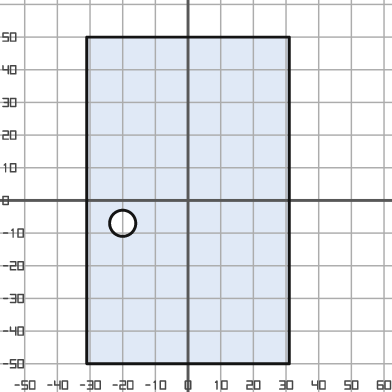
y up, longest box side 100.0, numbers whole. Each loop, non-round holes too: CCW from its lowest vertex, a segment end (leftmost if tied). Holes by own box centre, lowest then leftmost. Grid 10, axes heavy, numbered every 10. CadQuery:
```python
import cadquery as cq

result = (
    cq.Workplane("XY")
    .moveTo(-31.0, -50.0)
    .lineTo(31.0, -50.0)
    .lineTo(31.0, 50.0)
    .lineTo(-31.0, 50.0)
    .close()
    .moveTo(-20.0, -7.0)
    .circle(4.0)
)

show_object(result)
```